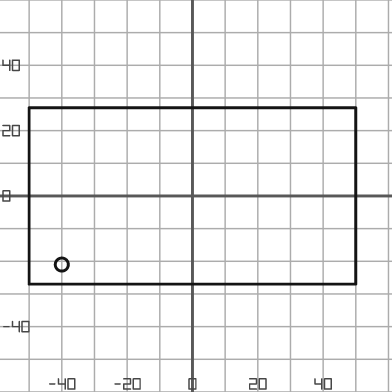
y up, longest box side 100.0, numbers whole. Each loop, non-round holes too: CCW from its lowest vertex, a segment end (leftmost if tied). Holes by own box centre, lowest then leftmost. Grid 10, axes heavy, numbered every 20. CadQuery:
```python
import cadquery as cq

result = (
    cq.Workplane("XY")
    .moveTo(-50.0, -27.0)
    .lineTo(50.0, -27.0)
    .lineTo(50.0, 27.0)
    .lineTo(-50.0, 27.0)
    .close()
    .moveTo(-40.0, -21.0)
    .circle(2.0)
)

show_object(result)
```